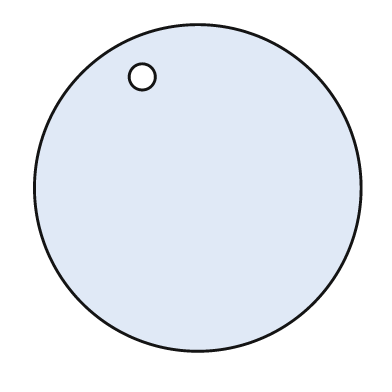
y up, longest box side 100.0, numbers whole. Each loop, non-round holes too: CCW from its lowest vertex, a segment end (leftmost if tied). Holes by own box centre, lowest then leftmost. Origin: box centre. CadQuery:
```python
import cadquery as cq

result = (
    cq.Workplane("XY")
    .moveTo(0.0, 0.0)
    .circle(50.0)
    .moveTo(-17.0, 34.0)
    .circle(4.0)
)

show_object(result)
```